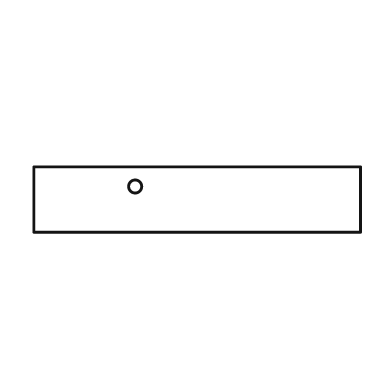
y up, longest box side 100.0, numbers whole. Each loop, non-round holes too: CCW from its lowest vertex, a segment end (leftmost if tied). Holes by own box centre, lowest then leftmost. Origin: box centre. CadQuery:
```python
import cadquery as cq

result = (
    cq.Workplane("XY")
    .moveTo(-50.0, -10.0)
    .lineTo(50.0, -10.0)
    .lineTo(50.0, 10.0)
    .lineTo(-50.0, 10.0)
    .close()
    .moveTo(-19.0, 4.0)
    .circle(2.0)
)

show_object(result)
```